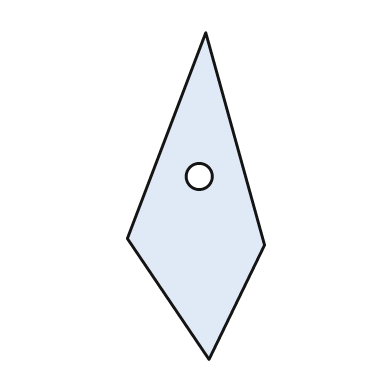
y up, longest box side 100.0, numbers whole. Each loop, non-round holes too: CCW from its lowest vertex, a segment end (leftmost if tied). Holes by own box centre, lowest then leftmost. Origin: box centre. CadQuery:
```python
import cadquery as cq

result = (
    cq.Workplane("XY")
    .moveTo(4.0, -50.0)
    .lineTo(21.0, -15.0)
    .lineTo(3.0, 50.0)
    .lineTo(-21.0, -13.0)
    .close()
    .moveTo(1.0, 6.0)
    .circle(4.0)
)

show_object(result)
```